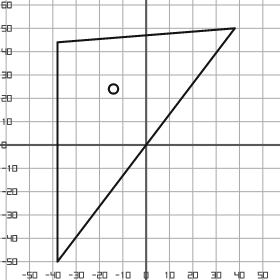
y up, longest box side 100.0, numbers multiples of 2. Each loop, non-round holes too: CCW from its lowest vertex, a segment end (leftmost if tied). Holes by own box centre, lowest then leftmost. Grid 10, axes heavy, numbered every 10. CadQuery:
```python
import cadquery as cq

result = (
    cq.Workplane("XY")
    .moveTo(-38.0, -50.0)
    .lineTo(38.0, 50.0)
    .lineTo(-38.0, 44.0)
    .close()
    .moveTo(-14.0, 24.0)
    .circle(2.0)
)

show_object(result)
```